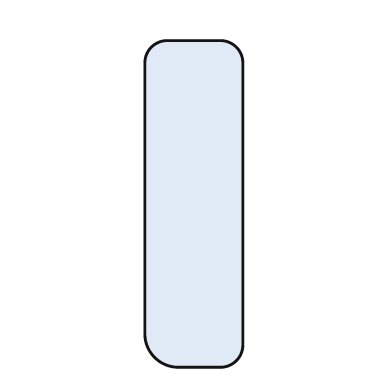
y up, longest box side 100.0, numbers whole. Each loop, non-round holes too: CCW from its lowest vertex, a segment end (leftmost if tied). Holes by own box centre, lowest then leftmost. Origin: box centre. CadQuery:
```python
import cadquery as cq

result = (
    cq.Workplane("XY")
    .moveTo(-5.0, -50.0)
    .lineTo(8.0, -50.0)
    .threePointArc((13.0, -48.0), (15.0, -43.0))
    .lineTo(15.0, 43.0)
    .threePointArc((13.0, 48.0), (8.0, 50.0))
    .lineTo(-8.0, 50.0)
    .threePointArc((-13.0, 48.0), (-15.0, 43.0))
    .lineTo(-15.0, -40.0)
    .threePointArc((-12.0, -47.0), (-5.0, -50.0))
    .close()
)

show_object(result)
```